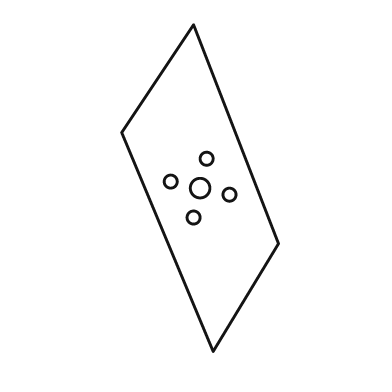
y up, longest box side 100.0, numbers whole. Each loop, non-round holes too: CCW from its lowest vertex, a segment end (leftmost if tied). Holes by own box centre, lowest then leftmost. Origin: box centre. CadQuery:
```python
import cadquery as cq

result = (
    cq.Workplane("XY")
    .moveTo(4.0, -50.0)
    .lineTo(24.0, -17.0)
    .lineTo(-2.0, 50.0)
    .lineTo(-24.0, 17.0)
    .close()
    .moveTo(-2.0, -9.0)
    .circle(2.0)
    .moveTo(9.0, -2.0)
    .circle(2.0)
    .moveTo(0.0, 0.0)
    .circle(3.0)
    .moveTo(-9.0, 2.0)
    .circle(2.0)
    .moveTo(2.0, 9.0)
    .circle(2.0)
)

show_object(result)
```